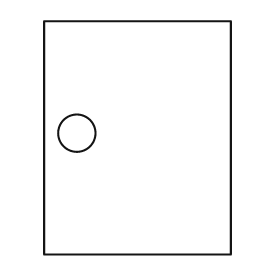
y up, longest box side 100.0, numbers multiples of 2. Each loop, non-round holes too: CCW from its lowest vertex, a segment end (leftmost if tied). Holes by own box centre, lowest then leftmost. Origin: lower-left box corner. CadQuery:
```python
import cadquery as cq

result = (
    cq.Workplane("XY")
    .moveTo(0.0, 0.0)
    .lineTo(80.0, 0.0)
    .lineTo(80.0, 100.0)
    .lineTo(0.0, 100.0)
    .close()
    .moveTo(14.0, 52.0)
    .circle(8.0)
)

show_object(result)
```